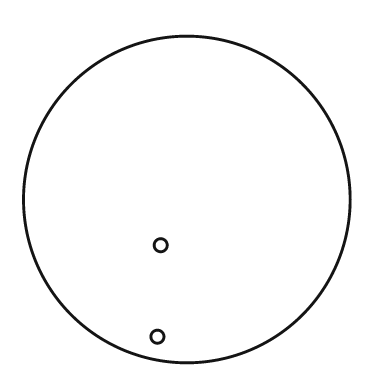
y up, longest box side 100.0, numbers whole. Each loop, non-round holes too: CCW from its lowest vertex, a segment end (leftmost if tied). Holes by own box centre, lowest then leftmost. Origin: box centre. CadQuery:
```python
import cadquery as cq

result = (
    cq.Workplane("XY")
    .moveTo(0.0, 0.0)
    .circle(50.0)
    .moveTo(-9.0, -42.0)
    .circle(2.0)
    .moveTo(-8.0, -14.0)
    .circle(2.0)
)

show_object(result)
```